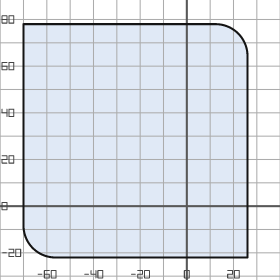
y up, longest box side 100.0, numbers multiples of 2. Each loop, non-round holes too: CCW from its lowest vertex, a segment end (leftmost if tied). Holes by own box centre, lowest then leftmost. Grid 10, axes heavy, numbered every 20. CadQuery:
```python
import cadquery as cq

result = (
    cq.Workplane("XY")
    .moveTo(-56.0, -22.0)
    .lineTo(26.0, -22.0)
    .lineTo(26.0, 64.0)
    .threePointArc((22.0, 74.0), (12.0, 78.0))
    .lineTo(-70.0, 78.0)
    .lineTo(-70.0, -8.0)
    .threePointArc((-66.0, -18.0), (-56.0, -22.0))
    .close()
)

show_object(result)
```